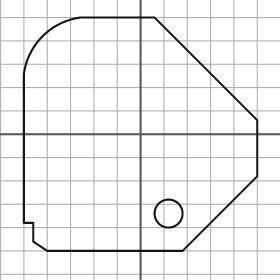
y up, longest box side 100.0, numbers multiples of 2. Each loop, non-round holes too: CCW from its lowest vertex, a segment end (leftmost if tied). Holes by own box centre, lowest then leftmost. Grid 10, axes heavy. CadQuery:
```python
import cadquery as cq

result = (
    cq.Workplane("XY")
    .moveTo(-40.0, -50.0)
    .lineTo(18.0, -50.0)
    .lineTo(50.0, -18.0)
    .lineTo(50.0, 6.0)
    .lineTo(6.0, 50.0)
    .lineTo(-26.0, 50.0)
    .threePointArc((-42.0, 42.0), (-50.0, 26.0))
    .lineTo(-50.0, -38.0)
    .lineTo(-46.0, -38.0)
    .lineTo(-46.0, -46.0)
    .close()
    .moveTo(12.0, -34.0)
    .circle(6.0)
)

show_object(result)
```